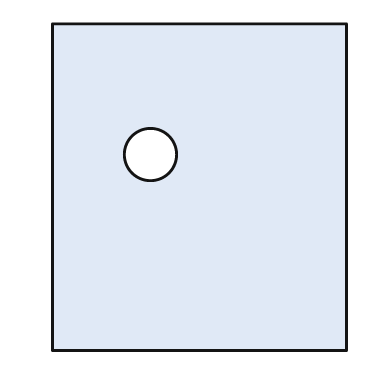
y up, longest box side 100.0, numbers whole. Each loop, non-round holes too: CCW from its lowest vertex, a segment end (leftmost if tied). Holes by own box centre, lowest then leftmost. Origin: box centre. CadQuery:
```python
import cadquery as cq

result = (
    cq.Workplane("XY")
    .moveTo(-45.0, -50.0)
    .lineTo(45.0, -50.0)
    .lineTo(45.0, 50.0)
    .lineTo(-45.0, 50.0)
    .close()
    .moveTo(-15.0, 10.0)
    .circle(8.0)
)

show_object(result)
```